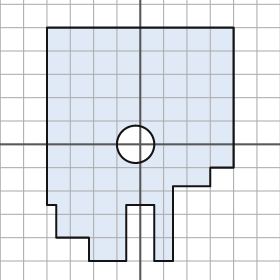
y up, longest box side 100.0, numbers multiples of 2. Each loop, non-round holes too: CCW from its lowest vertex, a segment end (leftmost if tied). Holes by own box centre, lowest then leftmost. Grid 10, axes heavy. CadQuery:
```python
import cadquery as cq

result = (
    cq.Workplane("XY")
    .moveTo(-22.0, -50.0)
    .lineTo(-6.0, -50.0)
    .lineTo(-6.0, -26.0)
    .lineTo(6.0, -26.0)
    .lineTo(6.0, -50.0)
    .lineTo(14.0, -50.0)
    .lineTo(14.0, -18.0)
    .lineTo(30.0, -18.0)
    .lineTo(30.0, -10.0)
    .lineTo(40.0, -10.0)
    .lineTo(40.0, 50.0)
    .lineTo(-40.0, 50.0)
    .lineTo(-40.0, -26.0)
    .lineTo(-36.0, -26.0)
    .lineTo(-36.0, -40.0)
    .lineTo(-22.0, -40.0)
    .close()
    .moveTo(-2.0, 0.0)
    .circle(8.0)
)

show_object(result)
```